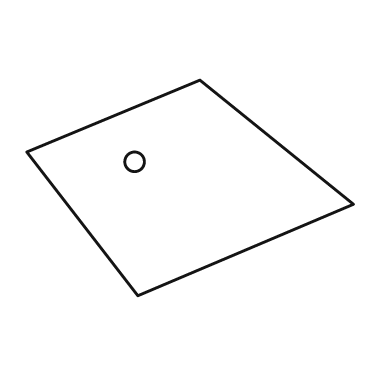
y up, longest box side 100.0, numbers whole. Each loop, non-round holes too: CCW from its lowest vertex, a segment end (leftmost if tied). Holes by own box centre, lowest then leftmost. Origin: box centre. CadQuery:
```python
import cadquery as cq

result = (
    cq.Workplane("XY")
    .moveTo(-16.0, -33.0)
    .lineTo(50.0, -5.0)
    .lineTo(3.0, 33.0)
    .lineTo(-50.0, 11.0)
    .close()
    .moveTo(-17.0, 8.0)
    .circle(3.0)
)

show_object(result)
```